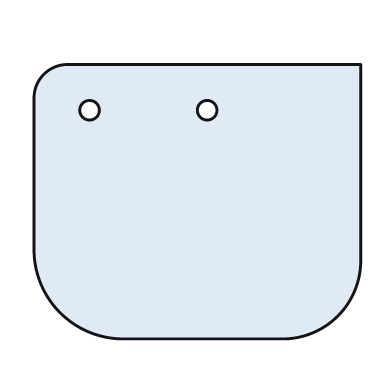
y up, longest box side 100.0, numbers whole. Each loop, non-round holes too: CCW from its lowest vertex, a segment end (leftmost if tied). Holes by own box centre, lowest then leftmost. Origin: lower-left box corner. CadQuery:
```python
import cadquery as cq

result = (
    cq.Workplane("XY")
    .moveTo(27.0, 0.0)
    .lineTo(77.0, 0.0)
    .threePointArc((93.0, 7.0), (100.0, 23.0))
    .lineTo(100.0, 84.0)
    .lineTo(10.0, 84.0)
    .threePointArc((3.0, 81.0), (0.0, 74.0))
    .lineTo(0.0, 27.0)
    .threePointArc((8.0, 8.0), (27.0, 0.0))
    .close()
    .moveTo(17.0, 70.0)
    .circle(3.0)
    .moveTo(53.0, 70.0)
    .circle(3.0)
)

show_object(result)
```